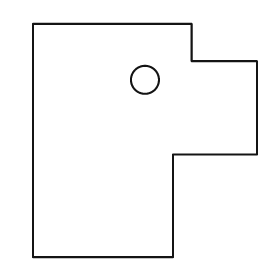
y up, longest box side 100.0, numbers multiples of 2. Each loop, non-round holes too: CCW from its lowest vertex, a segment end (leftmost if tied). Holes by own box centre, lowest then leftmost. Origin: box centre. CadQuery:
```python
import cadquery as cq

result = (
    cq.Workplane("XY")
    .moveTo(-48.0, -50.0)
    .lineTo(12.0, -50.0)
    .lineTo(12.0, -6.0)
    .lineTo(48.0, -6.0)
    .lineTo(48.0, 34.0)
    .lineTo(20.0, 34.0)
    .lineTo(20.0, 50.0)
    .lineTo(-48.0, 50.0)
    .close()
    .moveTo(0.0, 26.0)
    .circle(6.0)
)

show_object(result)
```